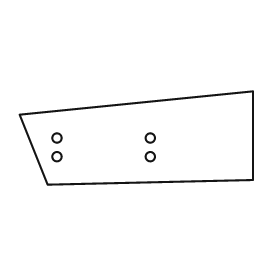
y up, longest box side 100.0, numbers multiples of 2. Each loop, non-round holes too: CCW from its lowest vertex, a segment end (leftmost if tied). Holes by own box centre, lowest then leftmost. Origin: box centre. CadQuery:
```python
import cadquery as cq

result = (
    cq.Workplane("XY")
    .moveTo(-38.0, -20.0)
    .lineTo(50.0, -18.0)
    .lineTo(50.0, 20.0)
    .lineTo(-50.0, 10.0)
    .close()
    .moveTo(-34.0, -8.0)
    .circle(2.0)
    .moveTo(6.0, -8.0)
    .circle(2.0)
    .moveTo(-34.0, 0.0)
    .circle(2.0)
    .moveTo(6.0, 0.0)
    .circle(2.0)
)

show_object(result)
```